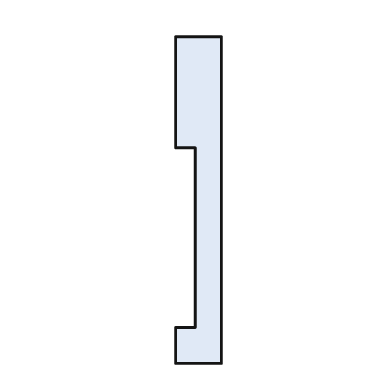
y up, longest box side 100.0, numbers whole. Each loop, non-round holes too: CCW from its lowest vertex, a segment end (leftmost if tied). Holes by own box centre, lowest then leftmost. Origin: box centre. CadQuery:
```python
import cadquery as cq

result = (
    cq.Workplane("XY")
    .moveTo(-7.0, -50.0)
    .lineTo(7.0, -50.0)
    .lineTo(7.0, 50.0)
    .lineTo(-7.0, 50.0)
    .lineTo(-7.0, 16.0)
    .lineTo(-1.0, 16.0)
    .lineTo(-1.0, -39.0)
    .lineTo(-7.0, -39.0)
    .close()
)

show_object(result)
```